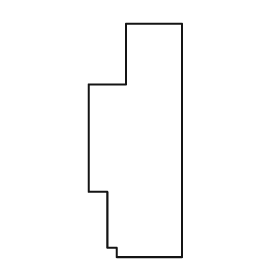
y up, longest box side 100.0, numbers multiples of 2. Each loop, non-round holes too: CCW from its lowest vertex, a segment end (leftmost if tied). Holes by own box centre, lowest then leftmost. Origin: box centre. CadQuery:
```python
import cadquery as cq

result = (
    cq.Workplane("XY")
    .moveTo(-8.0, -50.0)
    .lineTo(20.0, -50.0)
    .lineTo(20.0, 50.0)
    .lineTo(-4.0, 50.0)
    .lineTo(-4.0, 24.0)
    .lineTo(-20.0, 24.0)
    .lineTo(-20.0, -22.0)
    .lineTo(-12.0, -22.0)
    .lineTo(-12.0, -46.0)
    .lineTo(-8.0, -46.0)
    .close()
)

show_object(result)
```